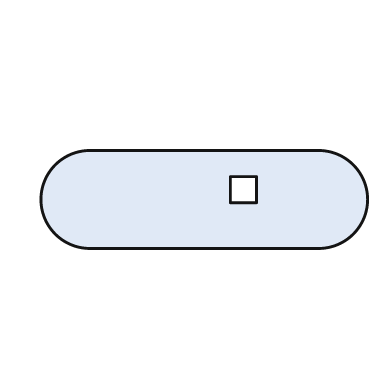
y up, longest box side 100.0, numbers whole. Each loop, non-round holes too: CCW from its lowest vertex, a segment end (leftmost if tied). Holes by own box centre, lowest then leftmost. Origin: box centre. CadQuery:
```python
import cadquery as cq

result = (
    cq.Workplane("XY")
    .moveTo(-35.0, -15.0)
    .lineTo(35.0, -15.0)
    .threePointArc((50.0, 0.0), (35.0, 15.0))
    .lineTo(-35.0, 15.0)
    .threePointArc((-50.0, 0.0), (-35.0, -15.0))
    .close()
    .moveTo(8.0, -1.0)
    .lineTo(16.0, -1.0)
    .lineTo(16.0, 7.0)
    .lineTo(8.0, 7.0)
    .close()
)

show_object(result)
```